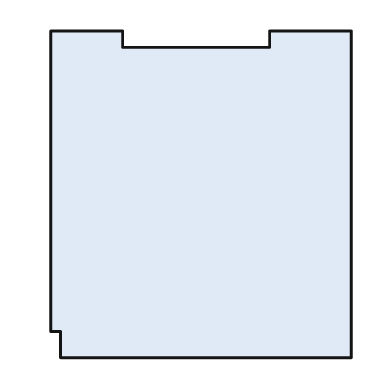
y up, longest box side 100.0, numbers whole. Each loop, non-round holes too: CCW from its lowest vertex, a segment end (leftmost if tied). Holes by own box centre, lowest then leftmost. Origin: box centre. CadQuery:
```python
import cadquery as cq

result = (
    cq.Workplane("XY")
    .moveTo(-43.0, -50.0)
    .lineTo(46.0, -50.0)
    .lineTo(46.0, 50.0)
    .lineTo(21.0, 50.0)
    .lineTo(21.0, 45.0)
    .lineTo(-24.0, 45.0)
    .lineTo(-24.0, 50.0)
    .lineTo(-46.0, 50.0)
    .lineTo(-46.0, -42.0)
    .lineTo(-43.0, -42.0)
    .close()
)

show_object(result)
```